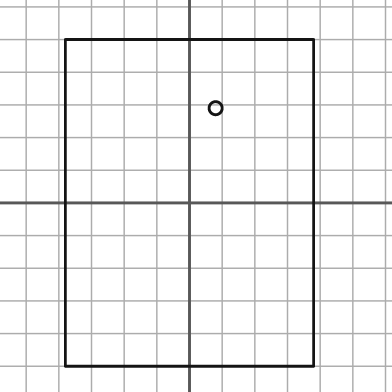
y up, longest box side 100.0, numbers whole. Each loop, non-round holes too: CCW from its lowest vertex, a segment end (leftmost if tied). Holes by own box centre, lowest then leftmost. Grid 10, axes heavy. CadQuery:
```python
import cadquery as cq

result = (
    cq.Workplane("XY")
    .moveTo(-38.0, -50.0)
    .lineTo(38.0, -50.0)
    .lineTo(38.0, 50.0)
    .lineTo(-38.0, 50.0)
    .close()
    .moveTo(8.0, 29.0)
    .circle(2.0)
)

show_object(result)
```